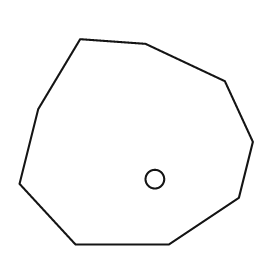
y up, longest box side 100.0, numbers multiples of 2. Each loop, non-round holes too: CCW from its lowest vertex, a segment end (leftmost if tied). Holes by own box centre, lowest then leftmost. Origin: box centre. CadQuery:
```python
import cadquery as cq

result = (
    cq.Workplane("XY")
    .moveTo(-26.0, -44.0)
    .lineTo(14.0, -44.0)
    .lineTo(44.0, -24.0)
    .lineTo(50.0, 0.0)
    .lineTo(38.0, 26.0)
    .lineTo(4.0, 42.0)
    .lineTo(-24.0, 44.0)
    .lineTo(-42.0, 14.0)
    .lineTo(-50.0, -18.0)
    .close()
    .moveTo(8.0, -16.0)
    .circle(4.0)
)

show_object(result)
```